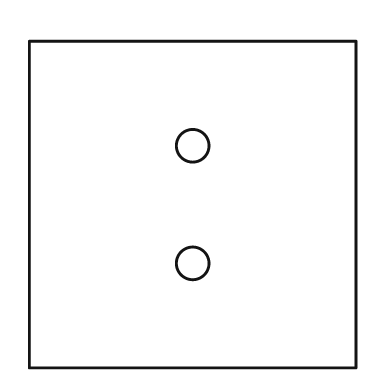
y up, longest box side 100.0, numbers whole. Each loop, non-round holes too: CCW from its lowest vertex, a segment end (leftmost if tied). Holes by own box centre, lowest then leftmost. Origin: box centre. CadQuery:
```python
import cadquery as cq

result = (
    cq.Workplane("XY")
    .moveTo(-50.0, -50.0)
    .lineTo(50.0, -50.0)
    .lineTo(50.0, 50.0)
    .lineTo(-50.0, 50.0)
    .close()
    .moveTo(0.0, -18.0)
    .circle(5.0)
    .moveTo(0.0, 18.0)
    .circle(5.0)
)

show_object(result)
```